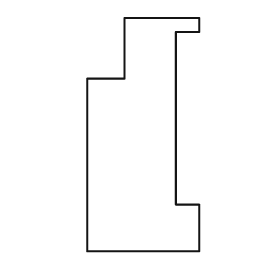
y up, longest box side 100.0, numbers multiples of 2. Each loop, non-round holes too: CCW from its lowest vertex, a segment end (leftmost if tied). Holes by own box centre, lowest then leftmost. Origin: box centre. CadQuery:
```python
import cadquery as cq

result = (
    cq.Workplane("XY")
    .moveTo(-24.0, -50.0)
    .lineTo(24.0, -50.0)
    .lineTo(24.0, -30.0)
    .lineTo(14.0, -30.0)
    .lineTo(14.0, 44.0)
    .lineTo(24.0, 44.0)
    .lineTo(24.0, 50.0)
    .lineTo(-8.0, 50.0)
    .lineTo(-8.0, 24.0)
    .lineTo(-24.0, 24.0)
    .close()
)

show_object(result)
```